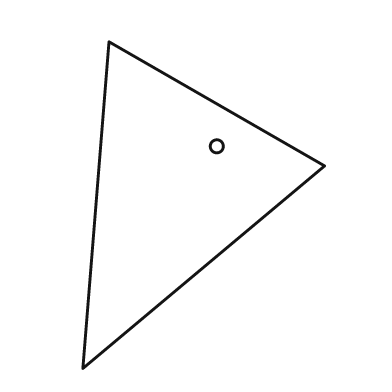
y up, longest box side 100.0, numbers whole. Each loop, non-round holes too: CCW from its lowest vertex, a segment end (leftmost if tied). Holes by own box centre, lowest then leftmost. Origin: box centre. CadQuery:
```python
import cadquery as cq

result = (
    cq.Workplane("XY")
    .moveTo(-37.0, -50.0)
    .lineTo(37.0, 12.0)
    .lineTo(-29.0, 50.0)
    .close()
    .moveTo(4.0, 18.0)
    .circle(2.0)
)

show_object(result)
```